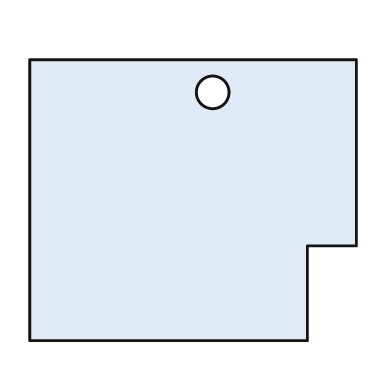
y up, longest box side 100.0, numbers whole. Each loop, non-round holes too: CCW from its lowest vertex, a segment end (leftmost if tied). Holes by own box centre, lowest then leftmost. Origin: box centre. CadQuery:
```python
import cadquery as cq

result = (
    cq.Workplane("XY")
    .moveTo(-50.0, -43.0)
    .lineTo(35.0, -43.0)
    .lineTo(35.0, -14.0)
    .lineTo(50.0, -14.0)
    .lineTo(50.0, 43.0)
    .lineTo(-50.0, 43.0)
    .close()
    .moveTo(6.0, 33.0)
    .circle(5.0)
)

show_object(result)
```